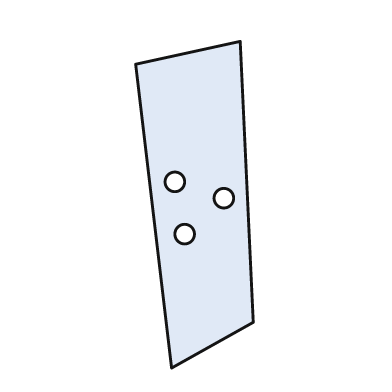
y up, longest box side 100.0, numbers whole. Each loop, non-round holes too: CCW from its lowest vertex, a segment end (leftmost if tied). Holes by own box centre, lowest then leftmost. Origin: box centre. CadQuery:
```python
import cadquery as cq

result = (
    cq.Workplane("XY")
    .moveTo(-7.0, -50.0)
    .lineTo(18.0, -36.0)
    .lineTo(14.0, 50.0)
    .lineTo(-18.0, 43.0)
    .close()
    .moveTo(-3.0, -9.0)
    .circle(3.0)
    .moveTo(9.0, 2.0)
    .circle(3.0)
    .moveTo(-6.0, 7.0)
    .circle(3.0)
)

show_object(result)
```